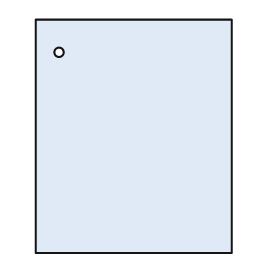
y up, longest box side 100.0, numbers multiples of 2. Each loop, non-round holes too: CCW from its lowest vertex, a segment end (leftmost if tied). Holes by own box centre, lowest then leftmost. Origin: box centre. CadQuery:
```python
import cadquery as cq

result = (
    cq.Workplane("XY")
    .moveTo(-42.0, -50.0)
    .lineTo(42.0, -50.0)
    .lineTo(42.0, 50.0)
    .lineTo(-42.0, 50.0)
    .close()
    .moveTo(-32.0, 36.0)
    .circle(2.0)
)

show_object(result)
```